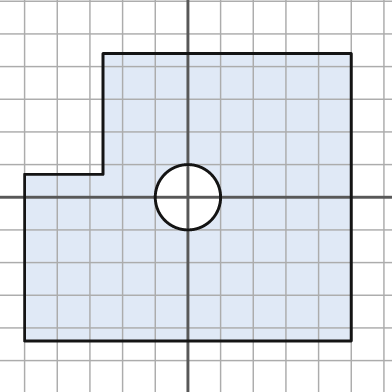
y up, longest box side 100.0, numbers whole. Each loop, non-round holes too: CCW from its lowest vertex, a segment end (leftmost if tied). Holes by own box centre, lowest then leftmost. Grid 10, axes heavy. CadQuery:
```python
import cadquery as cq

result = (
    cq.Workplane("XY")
    .moveTo(-50.0, -44.0)
    .lineTo(50.0, -44.0)
    .lineTo(50.0, 44.0)
    .lineTo(-26.0, 44.0)
    .lineTo(-26.0, 7.0)
    .lineTo(-50.0, 7.0)
    .close()
    .moveTo(0.0, 0.0)
    .circle(10.0)
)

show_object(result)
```